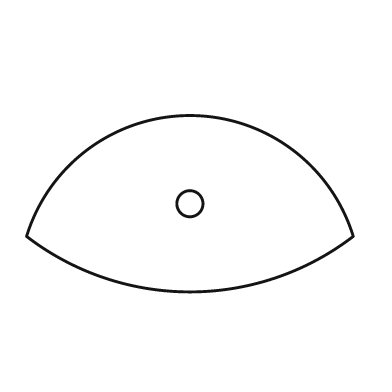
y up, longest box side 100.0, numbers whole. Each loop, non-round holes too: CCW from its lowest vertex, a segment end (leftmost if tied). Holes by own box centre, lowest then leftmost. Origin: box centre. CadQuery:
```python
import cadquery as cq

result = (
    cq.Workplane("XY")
    .moveTo(-50.0, -10.0)
    .threePointArc((0.0, -27.0), (50.0, -10.0))
    .threePointArc((0.0, 27.0), (-50.0, -10.0))
    .close()
    .moveTo(0.0, 0.0)
    .circle(4.0)
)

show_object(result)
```